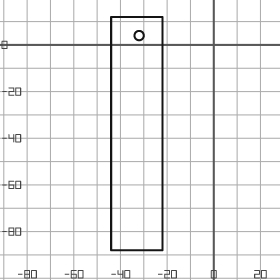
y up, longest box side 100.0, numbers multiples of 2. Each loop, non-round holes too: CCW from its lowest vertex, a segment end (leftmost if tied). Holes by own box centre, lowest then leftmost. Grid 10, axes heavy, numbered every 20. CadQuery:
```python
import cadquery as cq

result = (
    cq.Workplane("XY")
    .moveTo(-44.0, -88.0)
    .lineTo(-22.0, -88.0)
    .lineTo(-22.0, 12.0)
    .lineTo(-44.0, 12.0)
    .close()
    .moveTo(-32.0, 4.0)
    .circle(2.0)
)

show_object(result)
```